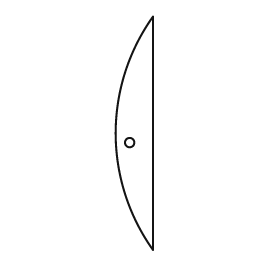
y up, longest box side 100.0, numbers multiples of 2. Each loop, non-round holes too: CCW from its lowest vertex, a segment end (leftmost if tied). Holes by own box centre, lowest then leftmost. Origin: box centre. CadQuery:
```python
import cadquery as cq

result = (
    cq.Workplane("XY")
    .moveTo(8.0, -50.0)
    .lineTo(8.0, 50.0)
    .threePointArc((-8.0, 0.0), (8.0, -50.0))
    .close()
    .moveTo(-2.0, -4.0)
    .circle(2.0)
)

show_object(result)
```